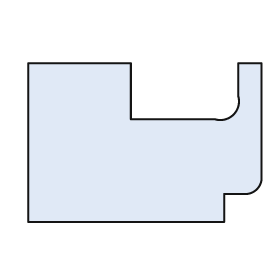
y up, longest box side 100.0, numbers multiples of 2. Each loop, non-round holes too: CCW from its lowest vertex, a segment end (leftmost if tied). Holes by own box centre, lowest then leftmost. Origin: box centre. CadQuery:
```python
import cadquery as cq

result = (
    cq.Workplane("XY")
    .moveTo(-50.0, -34.0)
    .lineTo(34.0, -34.0)
    .lineTo(34.0, -22.0)
    .lineTo(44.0, -22.0)
    .threePointArc((48.0, -20.0), (50.0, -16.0))
    .lineTo(50.0, 34.0)
    .lineTo(40.0, 34.0)
    .lineTo(40.0, 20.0)
    .threePointArc((38.0, 12.0), (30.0, 10.0))
    .lineTo(-6.0, 10.0)
    .lineTo(-6.0, 34.0)
    .lineTo(-50.0, 34.0)
    .close()
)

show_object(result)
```